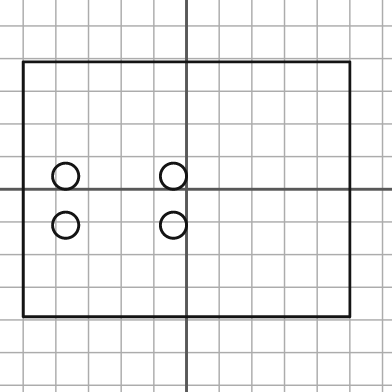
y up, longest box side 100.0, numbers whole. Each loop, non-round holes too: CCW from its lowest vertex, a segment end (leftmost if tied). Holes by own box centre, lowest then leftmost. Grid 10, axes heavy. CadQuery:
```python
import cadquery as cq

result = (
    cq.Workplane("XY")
    .moveTo(-50.0, -39.0)
    .lineTo(50.0, -39.0)
    .lineTo(50.0, 39.0)
    .lineTo(-50.0, 39.0)
    .close()
    .moveTo(-37.0, -11.0)
    .circle(4.0)
    .moveTo(-4.0, -11.0)
    .circle(4.0)
    .moveTo(-37.0, 4.0)
    .circle(4.0)
    .moveTo(-4.0, 4.0)
    .circle(4.0)
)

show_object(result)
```